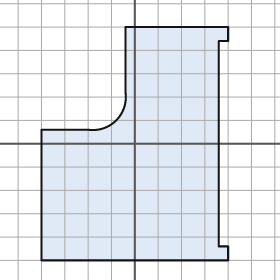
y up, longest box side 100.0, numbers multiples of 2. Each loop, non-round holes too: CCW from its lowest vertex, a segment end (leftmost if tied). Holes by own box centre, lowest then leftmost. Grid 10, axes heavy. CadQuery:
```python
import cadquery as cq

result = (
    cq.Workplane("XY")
    .moveTo(-40.0, -50.0)
    .lineTo(40.0, -50.0)
    .lineTo(40.0, -44.0)
    .lineTo(36.0, -44.0)
    .lineTo(36.0, 44.0)
    .lineTo(40.0, 44.0)
    .lineTo(40.0, 50.0)
    .lineTo(-4.0, 50.0)
    .lineTo(-4.0, 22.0)
    .threePointArc((-8.0, 10.0), (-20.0, 6.0))
    .lineTo(-40.0, 6.0)
    .close()
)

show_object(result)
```